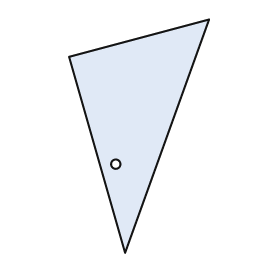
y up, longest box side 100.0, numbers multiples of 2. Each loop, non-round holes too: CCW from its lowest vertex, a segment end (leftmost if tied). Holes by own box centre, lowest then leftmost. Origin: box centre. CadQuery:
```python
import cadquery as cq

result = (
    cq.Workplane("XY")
    .moveTo(-6.0, -50.0)
    .lineTo(30.0, 50.0)
    .lineTo(-30.0, 34.0)
    .close()
    .moveTo(-10.0, -12.0)
    .circle(2.0)
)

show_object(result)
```